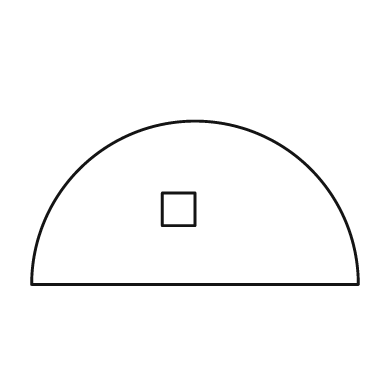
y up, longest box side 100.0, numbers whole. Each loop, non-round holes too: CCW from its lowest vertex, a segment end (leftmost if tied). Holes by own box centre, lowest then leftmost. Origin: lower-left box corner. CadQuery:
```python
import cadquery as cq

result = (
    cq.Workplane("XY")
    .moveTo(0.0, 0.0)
    .lineTo(100.0, 0.0)
    .threePointArc((50.0, 50.0), (0.0, 0.0))
    .close()
    .moveTo(40.0, 18.0)
    .lineTo(50.0, 18.0)
    .lineTo(50.0, 28.0)
    .lineTo(40.0, 28.0)
    .close()
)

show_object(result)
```